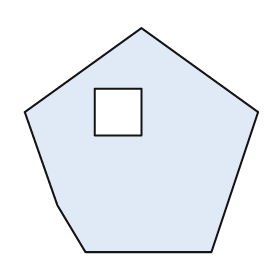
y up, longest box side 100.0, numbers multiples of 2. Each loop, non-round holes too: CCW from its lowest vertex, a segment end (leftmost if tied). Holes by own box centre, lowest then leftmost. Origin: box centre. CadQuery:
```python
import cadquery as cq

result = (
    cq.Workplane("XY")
    .moveTo(-24.0, -48.0)
    .lineTo(30.0, -48.0)
    .lineTo(50.0, 12.0)
    .lineTo(0.0, 48.0)
    .lineTo(-50.0, 12.0)
    .lineTo(-36.0, -28.0)
    .close()
    .moveTo(-20.0, 2.0)
    .lineTo(0.0, 2.0)
    .lineTo(0.0, 22.0)
    .lineTo(-20.0, 22.0)
    .close()
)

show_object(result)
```